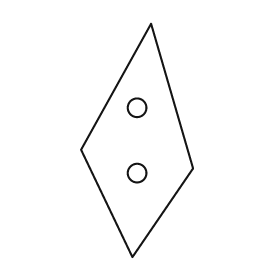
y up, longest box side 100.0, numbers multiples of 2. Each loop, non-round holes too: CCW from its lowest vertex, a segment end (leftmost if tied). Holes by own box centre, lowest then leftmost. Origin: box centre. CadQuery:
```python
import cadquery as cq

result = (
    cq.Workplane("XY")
    .moveTo(-2.0, -50.0)
    .lineTo(24.0, -12.0)
    .lineTo(6.0, 50.0)
    .lineTo(-24.0, -4.0)
    .close()
    .moveTo(0.0, -14.0)
    .circle(4.0)
    .moveTo(0.0, 14.0)
    .circle(4.0)
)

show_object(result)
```